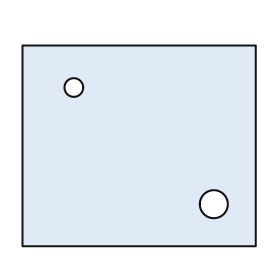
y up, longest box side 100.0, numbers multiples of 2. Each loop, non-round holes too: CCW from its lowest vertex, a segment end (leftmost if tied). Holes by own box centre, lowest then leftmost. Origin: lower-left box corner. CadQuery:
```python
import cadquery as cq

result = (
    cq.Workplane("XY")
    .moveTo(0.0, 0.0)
    .lineTo(100.0, 0.0)
    .lineTo(100.0, 86.0)
    .lineTo(0.0, 86.0)
    .close()
    .moveTo(82.0, 18.0)
    .circle(6.0)
    .moveTo(22.0, 68.0)
    .circle(4.0)
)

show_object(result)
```